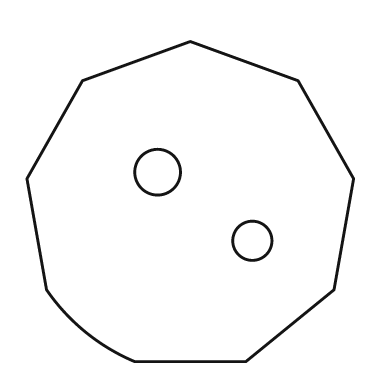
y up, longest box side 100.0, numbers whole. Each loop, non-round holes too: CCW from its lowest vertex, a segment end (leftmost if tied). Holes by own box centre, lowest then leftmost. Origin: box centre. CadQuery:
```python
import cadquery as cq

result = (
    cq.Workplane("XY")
    .moveTo(-17.0, -49.0)
    .lineTo(17.0, -49.0)
    .lineTo(44.0, -27.0)
    .lineTo(50.0, 7.0)
    .lineTo(33.0, 37.0)
    .lineTo(0.0, 49.0)
    .lineTo(-33.0, 37.0)
    .lineTo(-50.0, 7.0)
    .lineTo(-44.0, -27.0)
    .threePointArc((-32.0, -40.0), (-17.0, -49.0))
    .close()
    .moveTo(19.0, -12.0)
    .circle(6.0)
    .moveTo(-10.0, 9.0)
    .circle(7.0)
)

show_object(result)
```